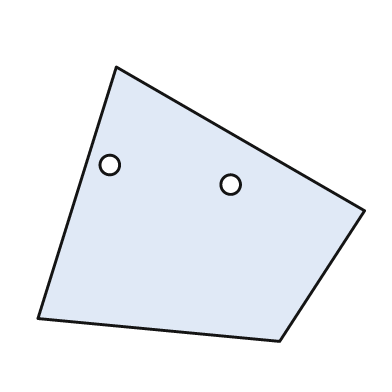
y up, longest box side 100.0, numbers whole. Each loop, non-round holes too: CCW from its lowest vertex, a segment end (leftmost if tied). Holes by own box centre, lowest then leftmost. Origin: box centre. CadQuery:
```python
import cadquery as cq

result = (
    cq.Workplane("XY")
    .moveTo(24.0, -42.0)
    .lineTo(50.0, -2.0)
    .lineTo(-26.0, 42.0)
    .lineTo(-50.0, -35.0)
    .close()
    .moveTo(9.0, 6.0)
    .circle(3.0)
    .moveTo(-28.0, 12.0)
    .circle(3.0)
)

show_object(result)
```